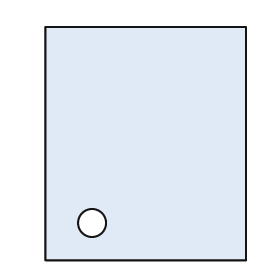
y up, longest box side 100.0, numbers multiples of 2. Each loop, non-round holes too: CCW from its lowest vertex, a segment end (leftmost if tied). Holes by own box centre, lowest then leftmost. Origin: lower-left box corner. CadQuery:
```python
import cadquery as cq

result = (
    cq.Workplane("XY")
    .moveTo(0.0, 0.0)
    .lineTo(86.0, 0.0)
    .lineTo(86.0, 100.0)
    .lineTo(0.0, 100.0)
    .close()
    .moveTo(20.0, 16.0)
    .circle(6.0)
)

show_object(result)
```